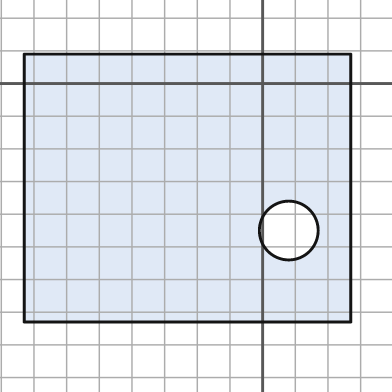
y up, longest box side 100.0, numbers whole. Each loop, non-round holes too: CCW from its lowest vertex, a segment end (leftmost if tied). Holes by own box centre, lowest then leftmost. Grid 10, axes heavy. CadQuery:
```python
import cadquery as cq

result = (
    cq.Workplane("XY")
    .moveTo(-73.0, -73.0)
    .lineTo(27.0, -73.0)
    .lineTo(27.0, 9.0)
    .lineTo(-73.0, 9.0)
    .close()
    .moveTo(8.0, -45.0)
    .circle(9.0)
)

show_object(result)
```